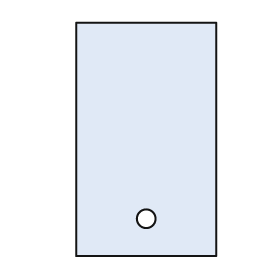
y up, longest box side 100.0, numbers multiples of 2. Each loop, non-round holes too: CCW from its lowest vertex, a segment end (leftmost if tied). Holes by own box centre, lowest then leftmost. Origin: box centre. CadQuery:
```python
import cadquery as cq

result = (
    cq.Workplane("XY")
    .moveTo(-30.0, -50.0)
    .lineTo(30.0, -50.0)
    .lineTo(30.0, 50.0)
    .lineTo(-30.0, 50.0)
    .close()
    .moveTo(0.0, -34.0)
    .circle(4.0)
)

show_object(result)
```